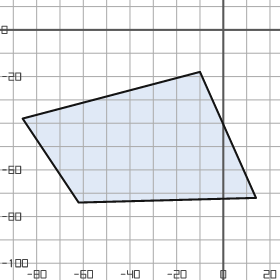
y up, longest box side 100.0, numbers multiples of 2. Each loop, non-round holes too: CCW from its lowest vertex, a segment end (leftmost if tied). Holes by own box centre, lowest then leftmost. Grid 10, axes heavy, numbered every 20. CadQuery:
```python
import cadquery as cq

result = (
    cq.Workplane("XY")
    .moveTo(-62.0, -74.0)
    .lineTo(14.0, -72.0)
    .lineTo(-10.0, -18.0)
    .lineTo(-86.0, -38.0)
    .close()
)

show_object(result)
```